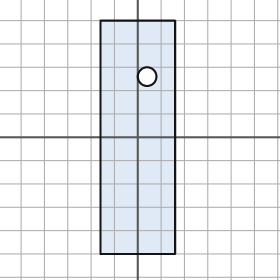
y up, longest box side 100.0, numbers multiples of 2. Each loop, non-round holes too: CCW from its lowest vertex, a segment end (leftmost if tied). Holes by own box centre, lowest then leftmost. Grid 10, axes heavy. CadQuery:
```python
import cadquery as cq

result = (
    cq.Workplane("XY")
    .moveTo(-16.0, -50.0)
    .lineTo(16.0, -50.0)
    .lineTo(16.0, 50.0)
    .lineTo(-16.0, 50.0)
    .close()
    .moveTo(4.0, 26.0)
    .circle(4.0)
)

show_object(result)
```